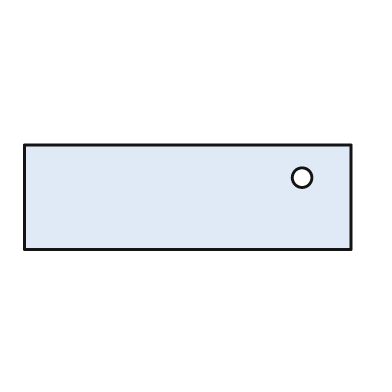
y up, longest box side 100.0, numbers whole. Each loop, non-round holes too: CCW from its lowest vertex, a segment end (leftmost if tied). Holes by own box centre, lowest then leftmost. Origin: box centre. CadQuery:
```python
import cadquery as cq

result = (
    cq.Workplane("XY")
    .moveTo(-50.0, -16.0)
    .lineTo(50.0, -16.0)
    .lineTo(50.0, 16.0)
    .lineTo(-50.0, 16.0)
    .close()
    .moveTo(35.0, 6.0)
    .circle(3.0)
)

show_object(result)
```